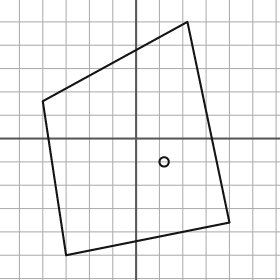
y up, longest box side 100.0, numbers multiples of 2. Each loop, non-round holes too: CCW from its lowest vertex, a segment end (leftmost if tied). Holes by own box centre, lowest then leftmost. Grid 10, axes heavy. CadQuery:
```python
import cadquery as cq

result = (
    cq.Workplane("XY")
    .moveTo(-30.0, -50.0)
    .lineTo(40.0, -36.0)
    .lineTo(22.0, 50.0)
    .lineTo(-40.0, 16.0)
    .close()
    .moveTo(12.0, -10.0)
    .circle(2.0)
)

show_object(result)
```